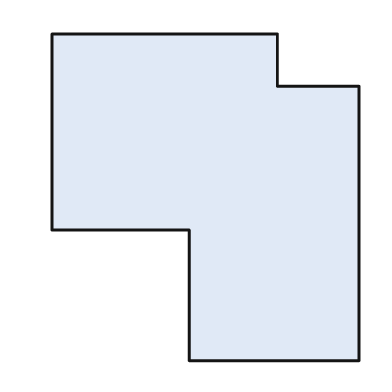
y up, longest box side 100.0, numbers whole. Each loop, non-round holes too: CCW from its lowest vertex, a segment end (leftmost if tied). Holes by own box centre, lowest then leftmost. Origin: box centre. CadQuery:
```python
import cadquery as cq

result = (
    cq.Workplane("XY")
    .moveTo(-5.0, -50.0)
    .lineTo(47.0, -50.0)
    .lineTo(47.0, 34.0)
    .lineTo(22.0, 34.0)
    .lineTo(22.0, 50.0)
    .lineTo(-47.0, 50.0)
    .lineTo(-47.0, -10.0)
    .lineTo(-5.0, -10.0)
    .close()
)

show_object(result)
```